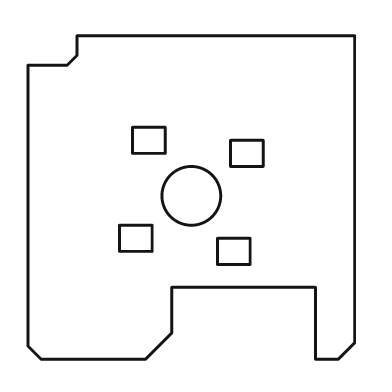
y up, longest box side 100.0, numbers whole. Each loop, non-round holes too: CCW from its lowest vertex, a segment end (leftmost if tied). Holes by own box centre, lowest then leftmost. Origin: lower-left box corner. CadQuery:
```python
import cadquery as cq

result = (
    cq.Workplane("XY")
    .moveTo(4.0, 0.0)
    .lineTo(36.0, 0.0)
    .lineTo(44.0, 8.0)
    .lineTo(44.0, 22.0)
    .lineTo(88.0, 22.0)
    .lineTo(88.0, 0.0)
    .lineTo(95.0, 0.0)
    .lineTo(100.0, 5.0)
    .lineTo(100.0, 99.0)
    .lineTo(15.0, 99.0)
    .lineTo(15.0, 93.0)
    .lineTo(12.0, 90.0)
    .lineTo(0.0, 90.0)
    .lineTo(0.0, 4.0)
    .close()
    .moveTo(58.0, 29.0)
    .lineTo(68.0, 29.0)
    .lineTo(68.0, 37.0)
    .lineTo(58.0, 37.0)
    .close()
    .moveTo(28.0, 33.0)
    .lineTo(38.0, 33.0)
    .lineTo(38.0, 41.0)
    .lineTo(28.0, 41.0)
    .close()
    .moveTo(50.0, 50.0)
    .circle(9.0)
    .moveTo(62.0, 59.0)
    .lineTo(72.0, 59.0)
    .lineTo(72.0, 67.0)
    .lineTo(62.0, 67.0)
    .close()
    .moveTo(32.0, 63.0)
    .lineTo(42.0, 63.0)
    .lineTo(42.0, 71.0)
    .lineTo(32.0, 71.0)
    .close()
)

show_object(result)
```